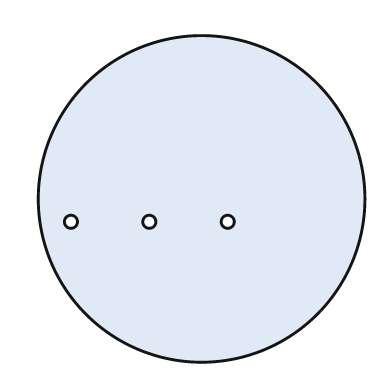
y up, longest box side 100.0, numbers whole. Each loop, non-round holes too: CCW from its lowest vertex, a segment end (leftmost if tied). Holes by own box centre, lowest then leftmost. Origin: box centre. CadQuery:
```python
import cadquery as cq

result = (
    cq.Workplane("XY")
    .moveTo(0.0, 0.0)
    .circle(50.0)
    .moveTo(-40.0, -7.0)
    .circle(2.0)
    .moveTo(-16.0, -7.0)
    .circle(2.0)
    .moveTo(8.0, -7.0)
    .circle(2.0)
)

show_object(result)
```